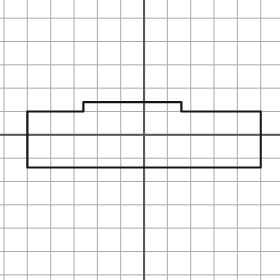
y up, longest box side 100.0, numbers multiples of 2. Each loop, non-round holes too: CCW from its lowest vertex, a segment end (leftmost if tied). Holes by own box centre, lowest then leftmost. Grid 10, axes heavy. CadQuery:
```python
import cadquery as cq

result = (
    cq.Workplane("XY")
    .moveTo(-50.0, -14.0)
    .lineTo(50.0, -14.0)
    .lineTo(50.0, 10.0)
    .lineTo(16.0, 10.0)
    .lineTo(16.0, 14.0)
    .lineTo(-26.0, 14.0)
    .lineTo(-26.0, 10.0)
    .lineTo(-50.0, 10.0)
    .close()
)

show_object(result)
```